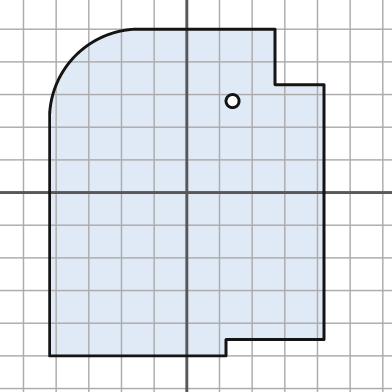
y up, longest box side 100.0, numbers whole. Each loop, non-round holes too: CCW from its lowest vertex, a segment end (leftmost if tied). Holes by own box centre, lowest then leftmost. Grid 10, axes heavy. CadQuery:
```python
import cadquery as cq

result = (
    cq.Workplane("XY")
    .moveTo(-42.0, -50.0)
    .lineTo(12.0, -50.0)
    .lineTo(12.0, -45.0)
    .lineTo(42.0, -45.0)
    .lineTo(42.0, 33.0)
    .lineTo(27.0, 33.0)
    .lineTo(27.0, 50.0)
    .lineTo(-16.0, 50.0)
    .threePointArc((-34.0, 42.0), (-42.0, 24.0))
    .close()
    .moveTo(14.0, 28.0)
    .circle(2.0)
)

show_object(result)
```